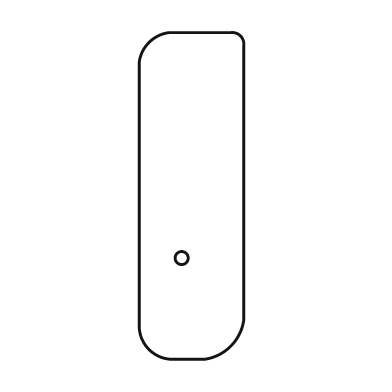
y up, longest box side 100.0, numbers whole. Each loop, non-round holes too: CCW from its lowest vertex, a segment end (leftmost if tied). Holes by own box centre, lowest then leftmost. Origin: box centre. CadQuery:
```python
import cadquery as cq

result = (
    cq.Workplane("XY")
    .moveTo(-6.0, -50.0)
    .lineTo(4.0, -50.0)
    .threePointArc((12.0, -46.0), (16.0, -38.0))
    .lineTo(16.0, 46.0)
    .threePointArc((15.0, 49.0), (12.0, 50.0))
    .lineTo(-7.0, 50.0)
    .threePointArc((-13.0, 47.0), (-16.0, 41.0))
    .lineTo(-16.0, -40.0)
    .threePointArc((-13.0, -47.0), (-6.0, -50.0))
    .close()
    .moveTo(-3.0, -19.0)
    .circle(2.0)
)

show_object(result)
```